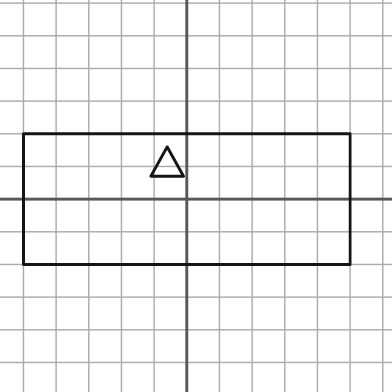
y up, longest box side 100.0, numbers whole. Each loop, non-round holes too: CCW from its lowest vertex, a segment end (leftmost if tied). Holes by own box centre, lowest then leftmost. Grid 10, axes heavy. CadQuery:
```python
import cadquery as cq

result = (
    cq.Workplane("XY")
    .moveTo(-50.0, -20.0)
    .lineTo(50.0, -20.0)
    .lineTo(50.0, 20.0)
    .lineTo(-50.0, 20.0)
    .close()
    .moveTo(-11.0, 7.0)
    .lineTo(-1.0, 7.0)
    .lineTo(-6.0, 16.0)
    .close()
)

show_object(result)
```